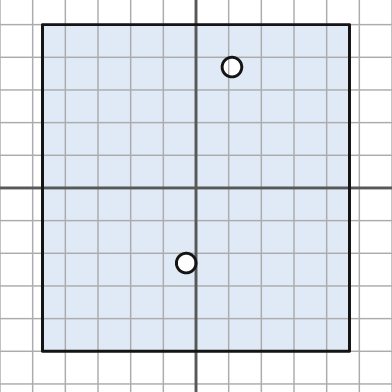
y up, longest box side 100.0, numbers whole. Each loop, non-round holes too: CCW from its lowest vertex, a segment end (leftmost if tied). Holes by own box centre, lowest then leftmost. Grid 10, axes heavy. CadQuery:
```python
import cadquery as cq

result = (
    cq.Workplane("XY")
    .moveTo(-47.0, -50.0)
    .lineTo(47.0, -50.0)
    .lineTo(47.0, 50.0)
    .lineTo(-47.0, 50.0)
    .close()
    .moveTo(-3.0, -23.0)
    .circle(3.0)
    .moveTo(11.0, 37.0)
    .circle(3.0)
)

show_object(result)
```